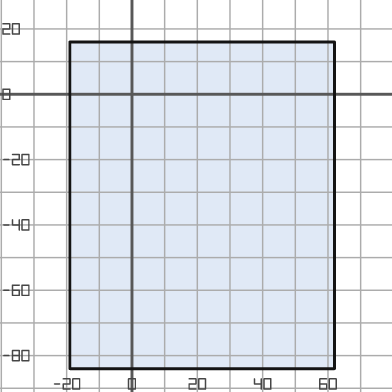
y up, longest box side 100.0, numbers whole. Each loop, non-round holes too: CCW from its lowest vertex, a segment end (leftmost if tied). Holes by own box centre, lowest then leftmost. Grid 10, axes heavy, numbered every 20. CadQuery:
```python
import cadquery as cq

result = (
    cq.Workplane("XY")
    .moveTo(-19.0, -84.0)
    .lineTo(62.0, -84.0)
    .lineTo(62.0, 16.0)
    .lineTo(-19.0, 16.0)
    .close()
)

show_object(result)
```